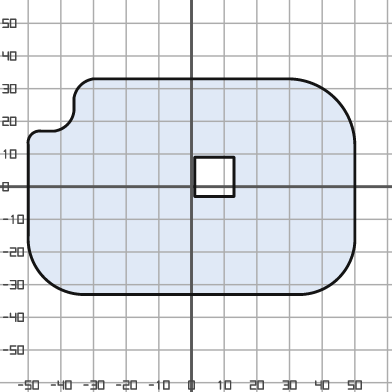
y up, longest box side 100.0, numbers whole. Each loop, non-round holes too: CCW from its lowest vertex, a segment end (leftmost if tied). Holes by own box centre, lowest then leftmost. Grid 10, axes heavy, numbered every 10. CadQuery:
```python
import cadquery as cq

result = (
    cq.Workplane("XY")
    .moveTo(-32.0, -33.0)
    .lineTo(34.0, -33.0)
    .threePointArc((45.0, -28.0), (50.0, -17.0))
    .lineTo(50.0, 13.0)
    .threePointArc((44.0, 27.0), (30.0, 33.0))
    .lineTo(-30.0, 33.0)
    .threePointArc((-34.0, 31.0), (-36.0, 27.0))
    .lineTo(-36.0, 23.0)
    .threePointArc((-38.0, 19.0), (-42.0, 17.0))
    .lineTo(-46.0, 17.0)
    .threePointArc((-49.0, 16.0), (-50.0, 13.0))
    .lineTo(-50.0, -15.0)
    .threePointArc((-45.0, -28.0), (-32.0, -33.0))
    .close()
    .moveTo(1.0, -3.0)
    .lineTo(13.0, -3.0)
    .lineTo(13.0, 9.0)
    .lineTo(1.0, 9.0)
    .close()
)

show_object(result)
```